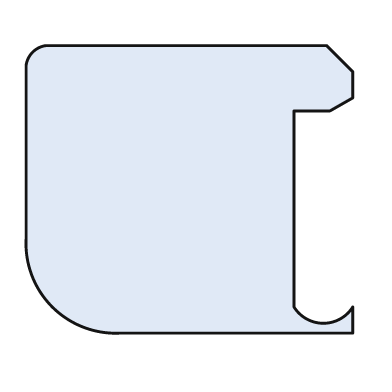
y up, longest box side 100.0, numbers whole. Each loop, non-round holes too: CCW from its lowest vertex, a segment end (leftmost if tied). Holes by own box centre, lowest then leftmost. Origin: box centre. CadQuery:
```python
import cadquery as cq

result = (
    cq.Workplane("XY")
    .moveTo(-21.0, -44.0)
    .lineTo(50.0, -44.0)
    .lineTo(50.0, -36.0)
    .threePointArc((41.0, -41.0), (32.0, -36.0))
    .lineTo(32.0, 24.0)
    .lineTo(43.0, 24.0)
    .lineTo(50.0, 28.0)
    .lineTo(50.0, 36.0)
    .lineTo(42.0, 44.0)
    .lineTo(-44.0, 44.0)
    .threePointArc((-48.0, 42.0), (-50.0, 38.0))
    .lineTo(-50.0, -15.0)
    .threePointArc((-42.0, -36.0), (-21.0, -44.0))
    .close()
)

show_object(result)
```